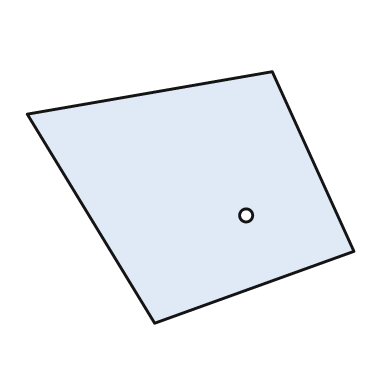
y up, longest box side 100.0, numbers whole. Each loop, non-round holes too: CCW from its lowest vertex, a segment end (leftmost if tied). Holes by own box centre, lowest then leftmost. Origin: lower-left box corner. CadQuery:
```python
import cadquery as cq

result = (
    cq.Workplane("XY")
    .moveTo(39.0, 0.0)
    .lineTo(100.0, 22.0)
    .lineTo(75.0, 77.0)
    .lineTo(0.0, 64.0)
    .close()
    .moveTo(67.0, 33.0)
    .circle(2.0)
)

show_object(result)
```